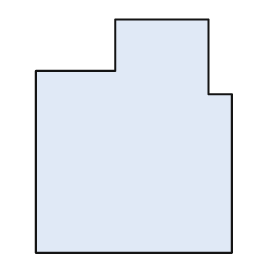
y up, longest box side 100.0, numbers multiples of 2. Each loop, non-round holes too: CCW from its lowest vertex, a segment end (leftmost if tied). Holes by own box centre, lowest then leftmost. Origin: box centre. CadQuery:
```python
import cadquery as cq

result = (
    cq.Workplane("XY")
    .moveTo(-42.0, -50.0)
    .lineTo(42.0, -50.0)
    .lineTo(42.0, 18.0)
    .lineTo(32.0, 18.0)
    .lineTo(32.0, 50.0)
    .lineTo(-8.0, 50.0)
    .lineTo(-8.0, 28.0)
    .lineTo(-42.0, 28.0)
    .close()
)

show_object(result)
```